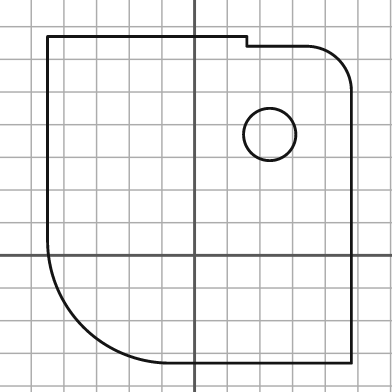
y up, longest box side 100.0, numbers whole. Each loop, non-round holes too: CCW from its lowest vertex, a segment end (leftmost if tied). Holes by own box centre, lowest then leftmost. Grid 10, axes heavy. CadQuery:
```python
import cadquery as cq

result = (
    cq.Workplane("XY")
    .moveTo(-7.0, -33.0)
    .lineTo(48.0, -33.0)
    .lineTo(48.0, 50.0)
    .threePointArc((44.0, 60.0), (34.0, 64.0))
    .lineTo(16.0, 64.0)
    .lineTo(16.0, 67.0)
    .lineTo(-45.0, 67.0)
    .lineTo(-45.0, 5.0)
    .threePointArc((-34.0, -22.0), (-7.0, -33.0))
    .close()
    .moveTo(23.0, 37.0)
    .circle(8.0)
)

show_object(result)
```